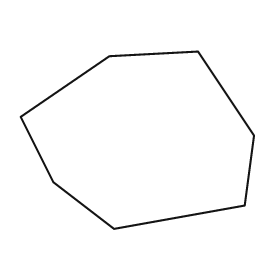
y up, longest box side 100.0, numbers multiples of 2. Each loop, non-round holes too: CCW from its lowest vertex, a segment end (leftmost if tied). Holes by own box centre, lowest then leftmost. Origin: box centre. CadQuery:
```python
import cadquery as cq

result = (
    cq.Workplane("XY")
    .moveTo(-10.0, -38.0)
    .lineTo(46.0, -28.0)
    .lineTo(50.0, 2.0)
    .lineTo(26.0, 38.0)
    .lineTo(-12.0, 36.0)
    .lineTo(-50.0, 10.0)
    .lineTo(-36.0, -18.0)
    .close()
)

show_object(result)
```